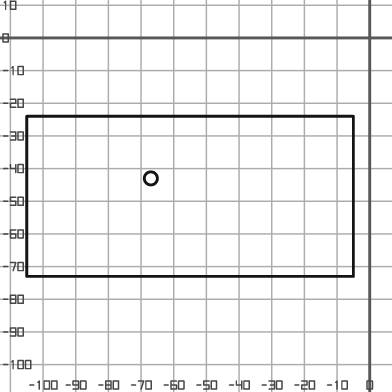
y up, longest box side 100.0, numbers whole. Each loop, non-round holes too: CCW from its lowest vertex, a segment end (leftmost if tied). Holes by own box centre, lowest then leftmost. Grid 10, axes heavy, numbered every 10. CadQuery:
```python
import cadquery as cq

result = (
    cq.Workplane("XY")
    .moveTo(-105.0, -73.0)
    .lineTo(-5.0, -73.0)
    .lineTo(-5.0, -24.0)
    .lineTo(-105.0, -24.0)
    .close()
    .moveTo(-67.0, -43.0)
    .circle(2.0)
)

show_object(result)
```